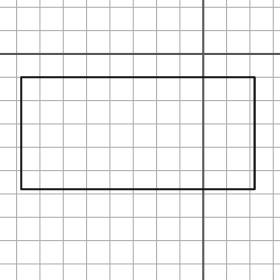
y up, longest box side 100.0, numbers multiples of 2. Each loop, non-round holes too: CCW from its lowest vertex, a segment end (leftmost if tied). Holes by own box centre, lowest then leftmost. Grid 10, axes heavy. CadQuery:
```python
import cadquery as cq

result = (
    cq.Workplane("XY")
    .moveTo(-78.0, -58.0)
    .lineTo(22.0, -58.0)
    .lineTo(22.0, -10.0)
    .lineTo(-78.0, -10.0)
    .close()
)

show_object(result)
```